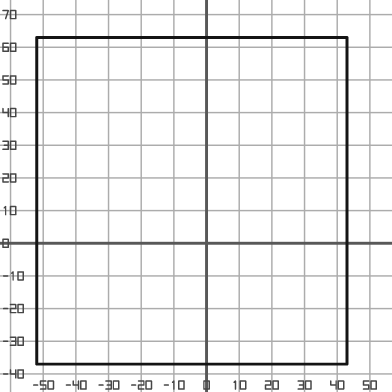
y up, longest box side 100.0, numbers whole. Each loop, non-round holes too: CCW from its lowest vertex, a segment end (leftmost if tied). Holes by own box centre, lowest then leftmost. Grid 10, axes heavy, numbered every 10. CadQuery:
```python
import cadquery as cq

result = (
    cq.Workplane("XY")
    .moveTo(-52.0, -37.0)
    .lineTo(43.0, -37.0)
    .lineTo(43.0, 63.0)
    .lineTo(-52.0, 63.0)
    .close()
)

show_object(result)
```